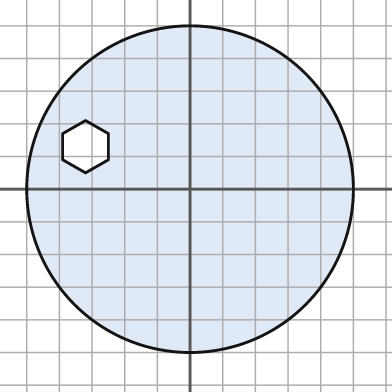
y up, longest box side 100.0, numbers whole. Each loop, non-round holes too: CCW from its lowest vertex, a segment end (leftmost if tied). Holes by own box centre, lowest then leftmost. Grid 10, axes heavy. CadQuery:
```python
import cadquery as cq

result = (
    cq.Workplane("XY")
    .moveTo(0.0, 0.0)
    .circle(50.0)
    .moveTo(-32.0, 5.0)
    .lineTo(-25.0, 9.0)
    .lineTo(-25.0, 17.0)
    .lineTo(-32.0, 21.0)
    .lineTo(-39.0, 17.0)
    .lineTo(-39.0, 9.0)
    .close()
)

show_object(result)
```